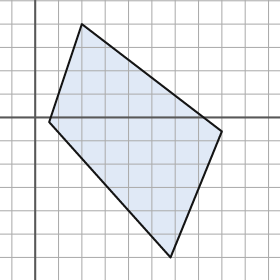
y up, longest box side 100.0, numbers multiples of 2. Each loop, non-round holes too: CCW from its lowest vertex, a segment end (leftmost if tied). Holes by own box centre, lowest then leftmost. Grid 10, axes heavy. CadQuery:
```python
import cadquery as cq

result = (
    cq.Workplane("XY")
    .moveTo(58.0, -60.0)
    .lineTo(80.0, -6.0)
    .lineTo(20.0, 40.0)
    .lineTo(6.0, -2.0)
    .close()
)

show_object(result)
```